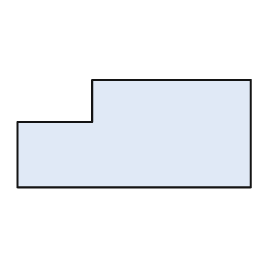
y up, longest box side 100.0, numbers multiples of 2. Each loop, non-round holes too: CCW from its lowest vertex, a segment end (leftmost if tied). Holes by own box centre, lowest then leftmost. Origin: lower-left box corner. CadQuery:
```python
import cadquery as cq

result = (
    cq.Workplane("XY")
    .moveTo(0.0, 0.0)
    .lineTo(100.0, 0.0)
    .lineTo(100.0, 46.0)
    .lineTo(32.0, 46.0)
    .lineTo(32.0, 28.0)
    .lineTo(0.0, 28.0)
    .close()
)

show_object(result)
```